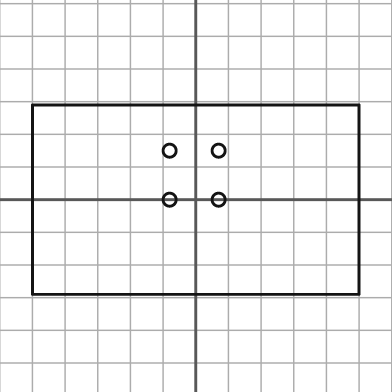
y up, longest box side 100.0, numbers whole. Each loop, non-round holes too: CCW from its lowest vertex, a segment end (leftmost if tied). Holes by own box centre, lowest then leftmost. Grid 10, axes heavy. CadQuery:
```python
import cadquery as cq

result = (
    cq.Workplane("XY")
    .moveTo(-50.0, -29.0)
    .lineTo(50.0, -29.0)
    .lineTo(50.0, 29.0)
    .lineTo(-50.0, 29.0)
    .close()
    .moveTo(-8.0, 0.0)
    .circle(2.0)
    .moveTo(7.0, 0.0)
    .circle(2.0)
    .moveTo(-8.0, 15.0)
    .circle(2.0)
    .moveTo(7.0, 15.0)
    .circle(2.0)
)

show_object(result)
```